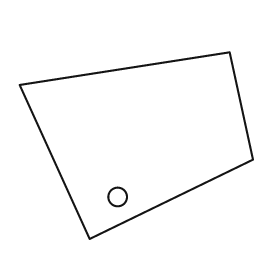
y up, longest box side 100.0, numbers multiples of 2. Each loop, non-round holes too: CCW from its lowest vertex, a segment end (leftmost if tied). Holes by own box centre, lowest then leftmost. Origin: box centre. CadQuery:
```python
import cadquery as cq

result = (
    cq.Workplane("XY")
    .moveTo(-20.0, -40.0)
    .lineTo(50.0, -6.0)
    .lineTo(40.0, 40.0)
    .lineTo(-50.0, 26.0)
    .close()
    .moveTo(-8.0, -22.0)
    .circle(4.0)
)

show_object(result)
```